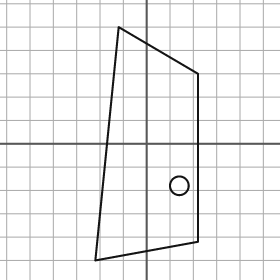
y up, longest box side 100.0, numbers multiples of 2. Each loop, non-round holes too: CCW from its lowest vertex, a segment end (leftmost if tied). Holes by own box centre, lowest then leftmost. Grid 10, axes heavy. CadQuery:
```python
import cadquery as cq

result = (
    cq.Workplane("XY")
    .moveTo(-22.0, -50.0)
    .lineTo(22.0, -42.0)
    .lineTo(22.0, 30.0)
    .lineTo(-12.0, 50.0)
    .close()
    .moveTo(14.0, -18.0)
    .circle(4.0)
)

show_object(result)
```